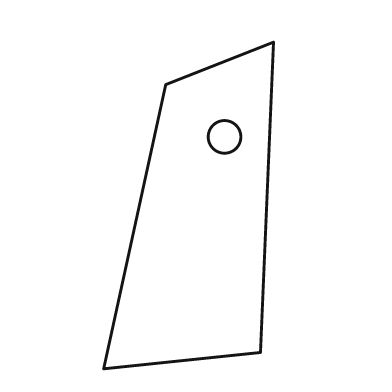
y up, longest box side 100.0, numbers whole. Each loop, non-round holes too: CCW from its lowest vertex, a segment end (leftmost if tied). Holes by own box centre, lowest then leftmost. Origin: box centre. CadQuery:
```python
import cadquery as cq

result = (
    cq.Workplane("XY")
    .moveTo(-26.0, -50.0)
    .lineTo(22.0, -45.0)
    .lineTo(26.0, 50.0)
    .lineTo(-7.0, 37.0)
    .close()
    .moveTo(11.0, 21.0)
    .circle(5.0)
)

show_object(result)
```